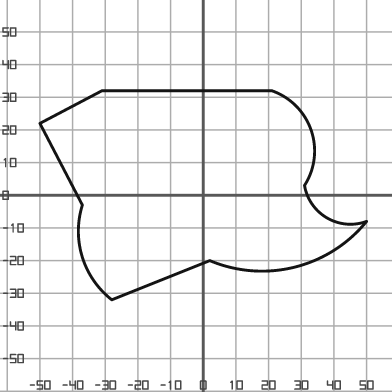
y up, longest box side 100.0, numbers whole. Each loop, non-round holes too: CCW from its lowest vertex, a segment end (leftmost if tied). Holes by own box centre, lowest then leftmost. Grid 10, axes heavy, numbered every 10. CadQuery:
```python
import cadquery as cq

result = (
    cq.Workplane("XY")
    .moveTo(-28.0, -32.0)
    .lineTo(2.0, -20.0)
    .threePointArc((28.0, -22.0), (50.0, -8.0))
    .threePointArc((38.0, -7.0), (31.0, 3.0))
    .threePointArc((33.0, 20.0), (21.0, 32.0))
    .lineTo(-31.0, 32.0)
    .lineTo(-50.0, 22.0)
    .lineTo(-37.0, -3.0)
    .threePointArc((-37.0, -19.0), (-28.0, -32.0))
    .close()
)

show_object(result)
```